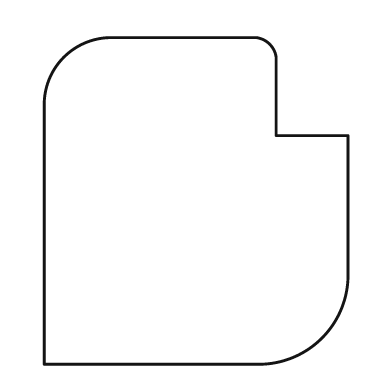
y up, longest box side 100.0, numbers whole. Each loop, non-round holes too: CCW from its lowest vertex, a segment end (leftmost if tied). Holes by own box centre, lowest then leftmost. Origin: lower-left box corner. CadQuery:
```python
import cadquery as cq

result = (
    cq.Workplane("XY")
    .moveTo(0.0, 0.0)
    .lineTo(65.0, 0.0)
    .threePointArc((85.0, 8.0), (93.0, 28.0))
    .lineTo(93.0, 70.0)
    .lineTo(71.0, 70.0)
    .lineTo(71.0, 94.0)
    .threePointArc((69.0, 98.0), (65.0, 100.0))
    .lineTo(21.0, 100.0)
    .threePointArc((6.0, 94.0), (0.0, 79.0))
    .close()
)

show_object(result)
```